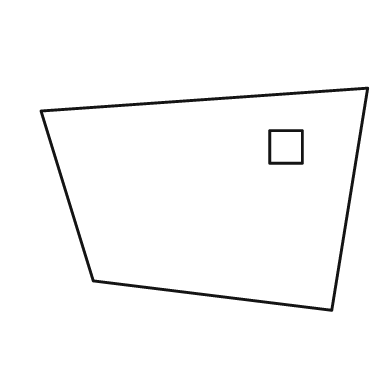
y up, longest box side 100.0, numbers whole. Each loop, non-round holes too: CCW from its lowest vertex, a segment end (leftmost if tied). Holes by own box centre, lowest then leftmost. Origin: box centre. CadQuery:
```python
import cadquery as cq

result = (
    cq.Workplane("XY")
    .moveTo(39.0, -34.0)
    .lineTo(50.0, 34.0)
    .lineTo(-50.0, 27.0)
    .lineTo(-34.0, -25.0)
    .close()
    .moveTo(20.0, 11.0)
    .lineTo(30.0, 11.0)
    .lineTo(30.0, 21.0)
    .lineTo(20.0, 21.0)
    .close()
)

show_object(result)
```